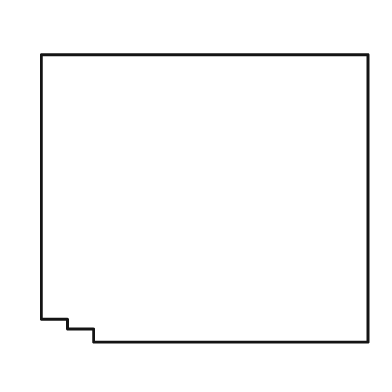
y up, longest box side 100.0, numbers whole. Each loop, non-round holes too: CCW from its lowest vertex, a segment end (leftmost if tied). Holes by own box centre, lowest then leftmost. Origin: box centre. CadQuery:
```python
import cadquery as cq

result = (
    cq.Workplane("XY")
    .moveTo(-34.0, -44.0)
    .lineTo(50.0, -44.0)
    .lineTo(50.0, 44.0)
    .lineTo(-50.0, 44.0)
    .lineTo(-50.0, -37.0)
    .lineTo(-42.0, -37.0)
    .lineTo(-42.0, -40.0)
    .lineTo(-34.0, -40.0)
    .close()
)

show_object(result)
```